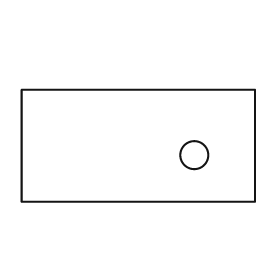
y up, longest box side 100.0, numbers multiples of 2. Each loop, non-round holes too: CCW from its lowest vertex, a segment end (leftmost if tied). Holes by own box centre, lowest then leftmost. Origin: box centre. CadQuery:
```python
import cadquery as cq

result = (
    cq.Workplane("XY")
    .moveTo(-50.0, -24.0)
    .lineTo(50.0, -24.0)
    .lineTo(50.0, 24.0)
    .lineTo(-50.0, 24.0)
    .close()
    .moveTo(24.0, -4.0)
    .circle(6.0)
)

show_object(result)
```